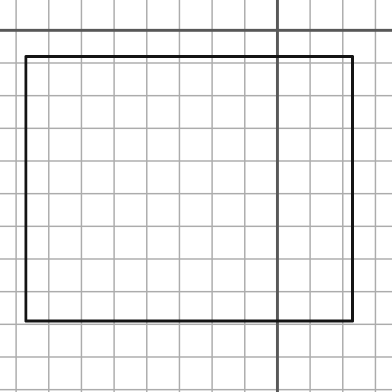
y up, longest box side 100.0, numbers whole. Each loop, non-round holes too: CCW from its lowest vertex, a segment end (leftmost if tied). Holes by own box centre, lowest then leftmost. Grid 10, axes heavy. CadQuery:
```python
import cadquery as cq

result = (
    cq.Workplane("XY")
    .moveTo(-77.0, -89.0)
    .lineTo(23.0, -89.0)
    .lineTo(23.0, -8.0)
    .lineTo(-77.0, -8.0)
    .close()
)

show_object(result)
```